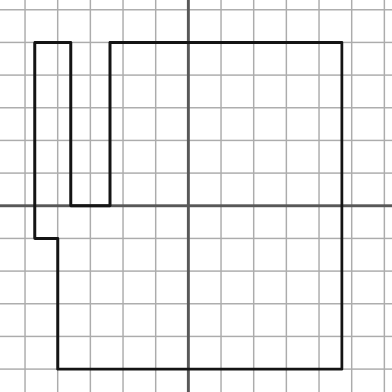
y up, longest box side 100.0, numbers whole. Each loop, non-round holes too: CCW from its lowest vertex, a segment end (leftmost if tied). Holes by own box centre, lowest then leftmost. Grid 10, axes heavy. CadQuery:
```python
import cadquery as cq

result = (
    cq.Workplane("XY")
    .moveTo(-40.0, -50.0)
    .lineTo(47.0, -50.0)
    .lineTo(47.0, 50.0)
    .lineTo(-24.0, 50.0)
    .lineTo(-24.0, 0.0)
    .lineTo(-36.0, 0.0)
    .lineTo(-36.0, 50.0)
    .lineTo(-47.0, 50.0)
    .lineTo(-47.0, -10.0)
    .lineTo(-40.0, -10.0)
    .close()
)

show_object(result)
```